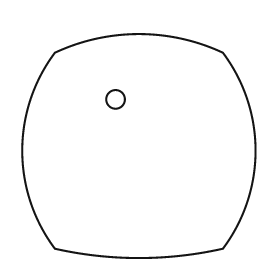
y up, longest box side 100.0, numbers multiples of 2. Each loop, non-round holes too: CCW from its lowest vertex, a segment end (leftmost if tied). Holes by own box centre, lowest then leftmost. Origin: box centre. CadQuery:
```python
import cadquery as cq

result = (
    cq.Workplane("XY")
    .moveTo(-36.0, -44.0)
    .threePointArc((0.0, -48.0), (36.0, -44.0))
    .threePointArc((50.0, -2.0), (36.0, 40.0))
    .threePointArc((0.0, 48.0), (-36.0, 40.0))
    .threePointArc((-50.0, -2.0), (-36.0, -44.0))
    .close()
    .moveTo(-10.0, 20.0)
    .circle(4.0)
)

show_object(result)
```